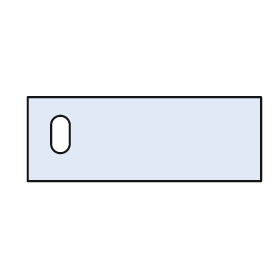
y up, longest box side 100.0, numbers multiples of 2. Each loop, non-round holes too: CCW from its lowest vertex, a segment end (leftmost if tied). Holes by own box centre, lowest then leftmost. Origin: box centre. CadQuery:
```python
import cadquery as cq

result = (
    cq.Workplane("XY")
    .moveTo(-50.0, -18.0)
    .lineTo(50.0, -18.0)
    .lineTo(50.0, 18.0)
    .lineTo(-50.0, 18.0)
    .close()
    .moveTo(-40.0, -2.0)
    .threePointArc((-36.0, -6.0), (-32.0, -2.0))
    .lineTo(-32.0, 6.0)
    .threePointArc((-36.0, 10.0), (-40.0, 6.0))
    .close()
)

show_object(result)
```